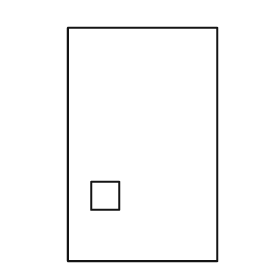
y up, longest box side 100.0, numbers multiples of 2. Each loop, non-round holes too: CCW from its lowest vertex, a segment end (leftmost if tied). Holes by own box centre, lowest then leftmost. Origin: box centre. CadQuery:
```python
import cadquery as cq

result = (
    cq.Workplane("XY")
    .moveTo(-32.0, -50.0)
    .lineTo(32.0, -50.0)
    .lineTo(32.0, 50.0)
    .lineTo(-32.0, 50.0)
    .close()
    .moveTo(-22.0, -28.0)
    .lineTo(-10.0, -28.0)
    .lineTo(-10.0, -16.0)
    .lineTo(-22.0, -16.0)
    .close()
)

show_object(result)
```